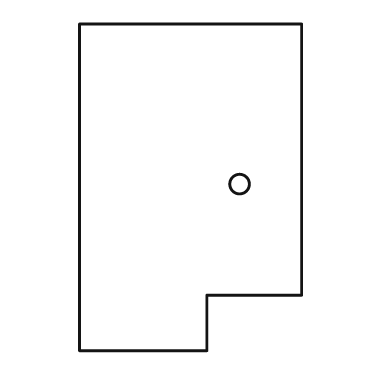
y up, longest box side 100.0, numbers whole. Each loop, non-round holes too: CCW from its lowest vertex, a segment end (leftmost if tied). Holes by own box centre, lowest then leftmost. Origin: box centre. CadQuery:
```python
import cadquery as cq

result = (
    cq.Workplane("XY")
    .moveTo(-34.0, -50.0)
    .lineTo(5.0, -50.0)
    .lineTo(5.0, -33.0)
    .lineTo(34.0, -33.0)
    .lineTo(34.0, 50.0)
    .lineTo(-34.0, 50.0)
    .close()
    .moveTo(15.0, 1.0)
    .circle(3.0)
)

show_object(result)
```